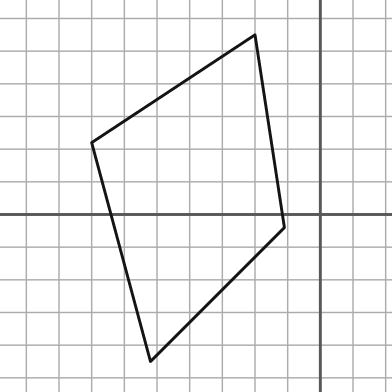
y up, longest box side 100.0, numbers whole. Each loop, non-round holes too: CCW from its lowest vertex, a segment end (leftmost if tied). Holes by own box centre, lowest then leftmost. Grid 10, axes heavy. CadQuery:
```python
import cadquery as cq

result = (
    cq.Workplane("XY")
    .moveTo(-52.0, -45.0)
    .lineTo(-11.0, -4.0)
    .lineTo(-20.0, 55.0)
    .lineTo(-70.0, 22.0)
    .close()
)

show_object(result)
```